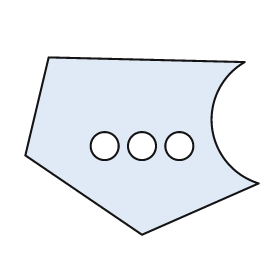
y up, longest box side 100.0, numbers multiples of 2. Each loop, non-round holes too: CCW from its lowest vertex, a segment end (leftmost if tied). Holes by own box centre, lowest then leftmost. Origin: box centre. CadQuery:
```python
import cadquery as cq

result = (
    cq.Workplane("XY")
    .moveTo(0.0, -38.0)
    .lineTo(50.0, -16.0)
    .threePointArc((30.0, 8.0), (44.0, 36.0))
    .lineTo(-40.0, 38.0)
    .lineTo(-50.0, -4.0)
    .close()
    .moveTo(-16.0, 0.0)
    .circle(6.0)
    .moveTo(0.0, 0.0)
    .circle(6.0)
    .moveTo(16.0, 0.0)
    .circle(6.0)
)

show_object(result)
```